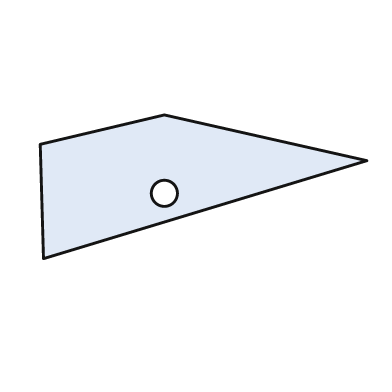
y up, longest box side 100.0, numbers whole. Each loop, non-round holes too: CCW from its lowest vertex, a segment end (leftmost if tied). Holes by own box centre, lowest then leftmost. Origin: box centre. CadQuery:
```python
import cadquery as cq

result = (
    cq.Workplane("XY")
    .moveTo(-49.0, -22.0)
    .lineTo(50.0, 8.0)
    .lineTo(-12.0, 22.0)
    .lineTo(-50.0, 13.0)
    .close()
    .moveTo(-12.0, -2.0)
    .circle(4.0)
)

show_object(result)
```